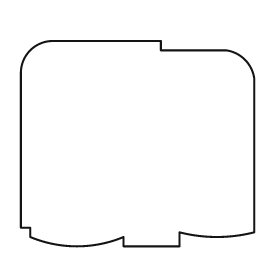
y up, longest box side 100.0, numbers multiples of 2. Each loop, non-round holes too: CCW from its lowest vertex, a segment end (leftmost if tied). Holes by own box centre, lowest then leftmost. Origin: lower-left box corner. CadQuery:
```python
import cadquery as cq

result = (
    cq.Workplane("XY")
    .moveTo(44.0, 0.0)
    .lineTo(68.0, 0.0)
    .lineTo(68.0, 6.0)
    .threePointArc((84.0, 4.0), (100.0, 6.0))
    .lineTo(100.0, 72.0)
    .threePointArc((96.0, 80.0), (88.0, 84.0))
    .lineTo(60.0, 84.0)
    .lineTo(60.0, 88.0)
    .lineTo(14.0, 88.0)
    .threePointArc((4.0, 84.0), (0.0, 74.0))
    .lineTo(0.0, 8.0)
    .lineTo(4.0, 8.0)
    .lineTo(4.0, 4.0)
    .threePointArc((24.0, 0.0), (44.0, 4.0))
    .close()
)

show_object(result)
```